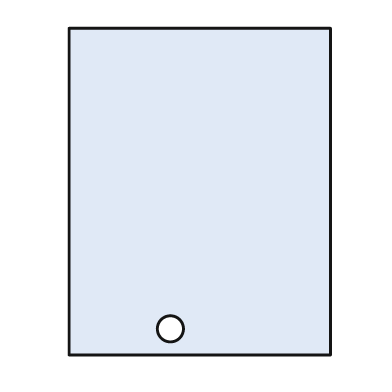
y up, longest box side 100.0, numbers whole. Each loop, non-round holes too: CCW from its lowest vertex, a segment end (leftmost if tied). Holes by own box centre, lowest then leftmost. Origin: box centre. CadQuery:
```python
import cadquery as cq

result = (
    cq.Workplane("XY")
    .moveTo(-40.0, -50.0)
    .lineTo(40.0, -50.0)
    .lineTo(40.0, 50.0)
    .lineTo(-40.0, 50.0)
    .close()
    .moveTo(-9.0, -42.0)
    .circle(4.0)
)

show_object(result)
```